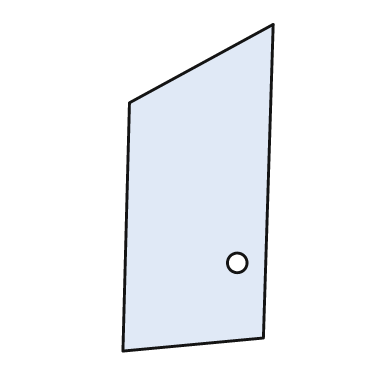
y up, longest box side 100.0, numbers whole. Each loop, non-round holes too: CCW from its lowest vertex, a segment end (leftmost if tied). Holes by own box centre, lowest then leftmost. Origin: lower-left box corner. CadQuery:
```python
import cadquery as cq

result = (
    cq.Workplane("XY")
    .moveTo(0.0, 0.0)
    .lineTo(43.0, 4.0)
    .lineTo(46.0, 100.0)
    .lineTo(2.0, 76.0)
    .close()
    .moveTo(35.0, 27.0)
    .circle(3.0)
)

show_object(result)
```